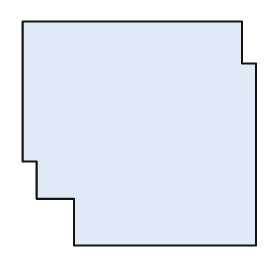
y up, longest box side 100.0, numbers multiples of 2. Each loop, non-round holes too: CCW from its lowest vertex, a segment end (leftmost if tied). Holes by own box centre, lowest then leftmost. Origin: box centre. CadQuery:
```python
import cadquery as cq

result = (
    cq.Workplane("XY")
    .moveTo(-28.0, -48.0)
    .lineTo(50.0, -48.0)
    .lineTo(50.0, 30.0)
    .lineTo(44.0, 30.0)
    .lineTo(44.0, 48.0)
    .lineTo(-50.0, 48.0)
    .lineTo(-50.0, -12.0)
    .lineTo(-44.0, -12.0)
    .lineTo(-44.0, -28.0)
    .lineTo(-28.0, -28.0)
    .close()
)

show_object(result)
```